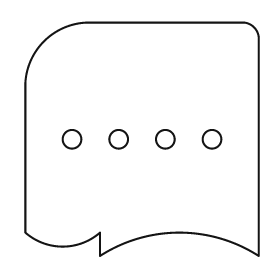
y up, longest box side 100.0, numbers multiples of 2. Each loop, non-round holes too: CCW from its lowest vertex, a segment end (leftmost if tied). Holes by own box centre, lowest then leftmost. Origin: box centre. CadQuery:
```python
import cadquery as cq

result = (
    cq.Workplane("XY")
    .moveTo(-18.0, -50.0)
    .threePointArc((16.0, -40.0), (50.0, -50.0))
    .lineTo(50.0, 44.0)
    .threePointArc((48.0, 48.0), (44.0, 50.0))
    .lineTo(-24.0, 50.0)
    .threePointArc((-42.0, 42.0), (-50.0, 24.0))
    .lineTo(-50.0, -40.0)
    .threePointArc((-34.0, -46.0), (-18.0, -40.0))
    .close()
    .moveTo(-30.0, 0.0)
    .circle(4.0)
    .moveTo(-10.0, 0.0)
    .circle(4.0)
    .moveTo(10.0, 0.0)
    .circle(4.0)
    .moveTo(30.0, 0.0)
    .circle(4.0)
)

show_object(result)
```